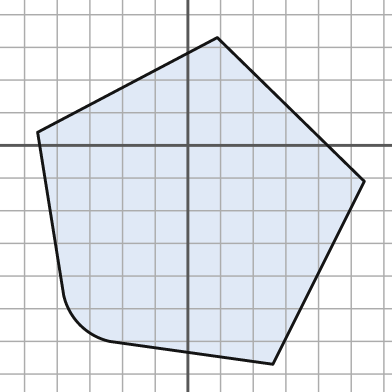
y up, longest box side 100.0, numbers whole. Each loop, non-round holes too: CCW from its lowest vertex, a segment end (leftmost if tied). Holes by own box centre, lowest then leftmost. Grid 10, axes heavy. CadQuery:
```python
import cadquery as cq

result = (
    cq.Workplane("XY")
    .moveTo(26.0, -67.0)
    .lineTo(54.0, -11.0)
    .lineTo(9.0, 33.0)
    .lineTo(-46.0, 4.0)
    .lineTo(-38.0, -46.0)
    .threePointArc((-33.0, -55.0), (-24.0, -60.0))
    .close()
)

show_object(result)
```